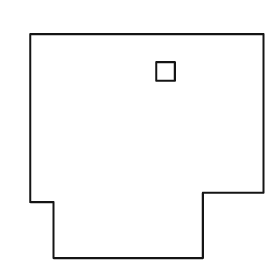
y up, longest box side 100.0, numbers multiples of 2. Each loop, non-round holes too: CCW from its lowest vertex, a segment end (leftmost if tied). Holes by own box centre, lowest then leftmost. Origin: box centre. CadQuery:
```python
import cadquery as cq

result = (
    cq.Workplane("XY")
    .moveTo(-40.0, -48.0)
    .lineTo(24.0, -48.0)
    .lineTo(24.0, -20.0)
    .lineTo(50.0, -20.0)
    .lineTo(50.0, 48.0)
    .lineTo(-50.0, 48.0)
    .lineTo(-50.0, -24.0)
    .lineTo(-40.0, -24.0)
    .close()
    .moveTo(4.0, 28.0)
    .lineTo(12.0, 28.0)
    .lineTo(12.0, 36.0)
    .lineTo(4.0, 36.0)
    .close()
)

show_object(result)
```